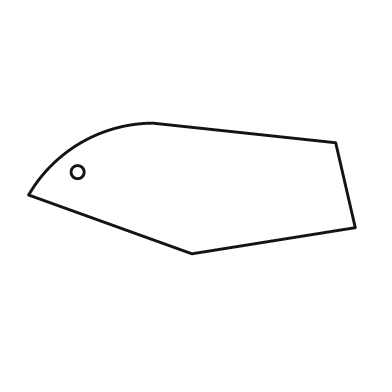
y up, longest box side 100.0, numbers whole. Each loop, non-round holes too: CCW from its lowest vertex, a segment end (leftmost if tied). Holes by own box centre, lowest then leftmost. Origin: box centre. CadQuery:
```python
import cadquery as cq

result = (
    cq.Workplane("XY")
    .moveTo(0.0, -20.0)
    .lineTo(50.0, -12.0)
    .lineTo(44.0, 14.0)
    .lineTo(-12.0, 20.0)
    .threePointArc((-34.0, 14.0), (-50.0, -2.0))
    .close()
    .moveTo(-35.0, 5.0)
    .circle(2.0)
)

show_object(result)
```